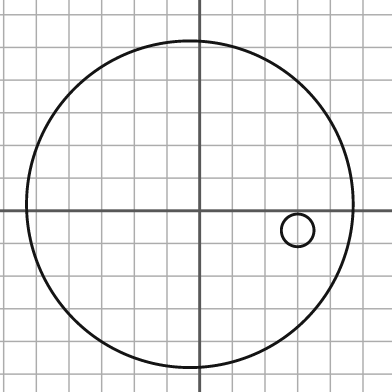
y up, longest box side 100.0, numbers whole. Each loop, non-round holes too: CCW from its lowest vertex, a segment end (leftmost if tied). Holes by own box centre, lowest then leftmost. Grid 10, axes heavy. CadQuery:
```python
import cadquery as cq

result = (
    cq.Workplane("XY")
    .moveTo(-3.0, 2.0)
    .circle(50.0)
    .moveTo(30.0, -6.0)
    .circle(5.0)
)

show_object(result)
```